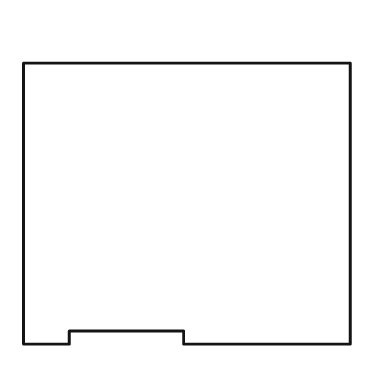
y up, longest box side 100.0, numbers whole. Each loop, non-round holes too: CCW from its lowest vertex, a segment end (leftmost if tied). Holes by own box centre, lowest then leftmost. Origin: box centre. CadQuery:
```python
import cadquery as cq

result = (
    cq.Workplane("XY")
    .moveTo(-50.0, -43.0)
    .lineTo(-36.0, -43.0)
    .lineTo(-36.0, -39.0)
    .lineTo(-1.0, -39.0)
    .lineTo(-1.0, -43.0)
    .lineTo(50.0, -43.0)
    .lineTo(50.0, 43.0)
    .lineTo(-50.0, 43.0)
    .close()
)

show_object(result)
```